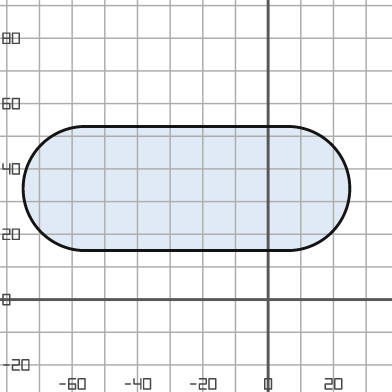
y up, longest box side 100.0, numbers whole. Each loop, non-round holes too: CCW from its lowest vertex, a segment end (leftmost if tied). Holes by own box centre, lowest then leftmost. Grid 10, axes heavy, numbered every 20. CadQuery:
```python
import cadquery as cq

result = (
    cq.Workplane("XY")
    .moveTo(-56.0, 15.0)
    .lineTo(6.0, 15.0)
    .threePointArc((25.0, 34.0), (6.0, 53.0))
    .lineTo(-56.0, 53.0)
    .threePointArc((-75.0, 34.0), (-56.0, 15.0))
    .close()
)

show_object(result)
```